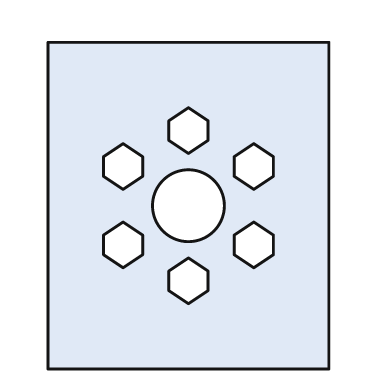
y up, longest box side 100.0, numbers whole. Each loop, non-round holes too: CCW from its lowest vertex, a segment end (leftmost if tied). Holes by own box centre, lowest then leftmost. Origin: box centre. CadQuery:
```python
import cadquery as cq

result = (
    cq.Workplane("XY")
    .moveTo(-43.0, -50.0)
    .lineTo(43.0, -50.0)
    .lineTo(43.0, 50.0)
    .lineTo(-43.0, 50.0)
    .close()
    .moveTo(0.0, -30.0)
    .lineTo(6.0, -26.0)
    .lineTo(6.0, -20.0)
    .lineTo(0.0, -16.0)
    .lineTo(-6.0, -20.0)
    .lineTo(-6.0, -26.0)
    .close()
    .moveTo(-20.0, -19.0)
    .lineTo(-14.0, -15.0)
    .lineTo(-14.0, -9.0)
    .lineTo(-20.0, -5.0)
    .lineTo(-26.0, -9.0)
    .lineTo(-26.0, -15.0)
    .close()
    .moveTo(20.0, -19.0)
    .lineTo(26.0, -15.0)
    .lineTo(26.0, -9.0)
    .lineTo(20.0, -5.0)
    .lineTo(14.0, -9.0)
    .lineTo(14.0, -15.0)
    .close()
    .moveTo(0.0, 0.0)
    .circle(11.0)
    .moveTo(-20.0, 5.0)
    .lineTo(-14.0, 9.0)
    .lineTo(-14.0, 15.0)
    .lineTo(-20.0, 19.0)
    .lineTo(-26.0, 15.0)
    .lineTo(-26.0, 9.0)
    .close()
    .moveTo(20.0, 5.0)
    .lineTo(26.0, 9.0)
    .lineTo(26.0, 15.0)
    .lineTo(20.0, 19.0)
    .lineTo(14.0, 15.0)
    .lineTo(14.0, 9.0)
    .close()
    .moveTo(0.0, 16.0)
    .lineTo(6.0, 20.0)
    .lineTo(6.0, 26.0)
    .lineTo(0.0, 30.0)
    .lineTo(-6.0, 26.0)
    .lineTo(-6.0, 20.0)
    .close()
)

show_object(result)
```